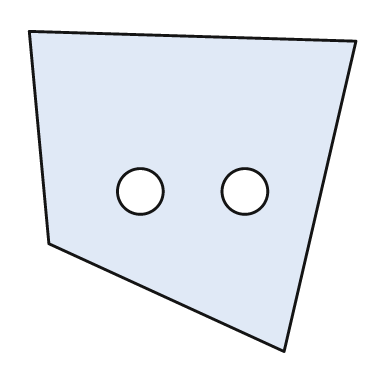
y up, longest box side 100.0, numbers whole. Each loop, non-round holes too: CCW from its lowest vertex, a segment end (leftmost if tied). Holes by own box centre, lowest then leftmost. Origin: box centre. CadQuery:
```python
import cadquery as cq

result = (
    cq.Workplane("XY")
    .moveTo(28.0, -49.0)
    .lineTo(50.0, 46.0)
    .lineTo(-50.0, 49.0)
    .lineTo(-44.0, -16.0)
    .close()
    .moveTo(-16.0, 0.0)
    .circle(7.0)
    .moveTo(16.0, 0.0)
    .circle(7.0)
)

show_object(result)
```